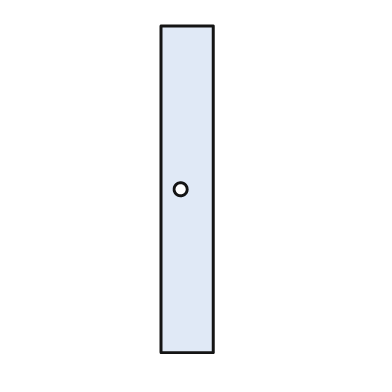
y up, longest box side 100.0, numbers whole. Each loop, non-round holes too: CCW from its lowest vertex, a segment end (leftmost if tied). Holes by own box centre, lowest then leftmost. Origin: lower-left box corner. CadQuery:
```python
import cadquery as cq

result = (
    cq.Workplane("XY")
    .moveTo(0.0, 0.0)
    .lineTo(16.0, 0.0)
    .lineTo(16.0, 100.0)
    .lineTo(0.0, 100.0)
    .close()
    .moveTo(6.0, 50.0)
    .circle(2.0)
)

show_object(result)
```